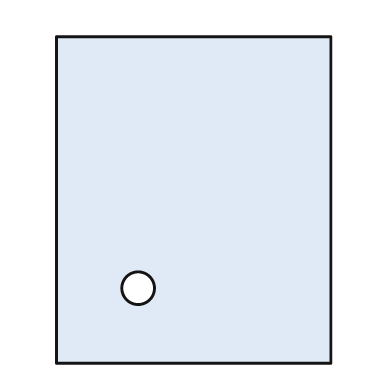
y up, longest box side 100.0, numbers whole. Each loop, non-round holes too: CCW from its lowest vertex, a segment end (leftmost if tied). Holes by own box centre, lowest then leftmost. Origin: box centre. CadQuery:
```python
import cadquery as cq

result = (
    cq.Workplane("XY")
    .moveTo(-42.0, -50.0)
    .lineTo(42.0, -50.0)
    .lineTo(42.0, 50.0)
    .lineTo(-42.0, 50.0)
    .close()
    .moveTo(-17.0, -27.0)
    .circle(5.0)
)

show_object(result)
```